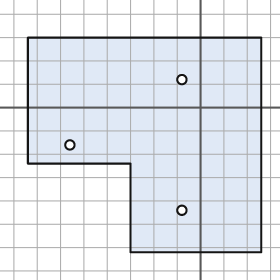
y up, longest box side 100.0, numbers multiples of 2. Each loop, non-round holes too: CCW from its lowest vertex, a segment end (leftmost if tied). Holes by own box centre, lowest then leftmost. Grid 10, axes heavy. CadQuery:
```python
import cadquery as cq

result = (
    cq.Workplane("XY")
    .moveTo(-30.0, -62.0)
    .lineTo(26.0, -62.0)
    .lineTo(26.0, 30.0)
    .lineTo(-74.0, 30.0)
    .lineTo(-74.0, -24.0)
    .lineTo(-30.0, -24.0)
    .close()
    .moveTo(-8.0, -44.0)
    .circle(2.0)
    .moveTo(-56.0, -16.0)
    .circle(2.0)
    .moveTo(-8.0, 12.0)
    .circle(2.0)
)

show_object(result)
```